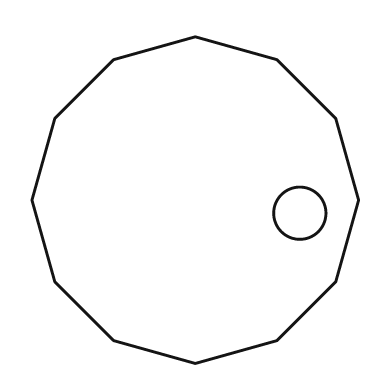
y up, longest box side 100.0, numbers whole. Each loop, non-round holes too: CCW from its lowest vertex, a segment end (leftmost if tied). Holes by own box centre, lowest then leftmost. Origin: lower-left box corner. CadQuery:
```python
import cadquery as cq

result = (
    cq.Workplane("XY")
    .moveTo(50.0, 0.0)
    .lineTo(75.0, 7.0)
    .lineTo(93.0, 25.0)
    .lineTo(100.0, 50.0)
    .lineTo(93.0, 75.0)
    .lineTo(75.0, 93.0)
    .lineTo(50.0, 100.0)
    .lineTo(25.0, 93.0)
    .lineTo(7.0, 75.0)
    .lineTo(0.0, 50.0)
    .lineTo(7.0, 25.0)
    .lineTo(25.0, 7.0)
    .close()
    .moveTo(82.0, 46.0)
    .circle(8.0)
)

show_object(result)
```